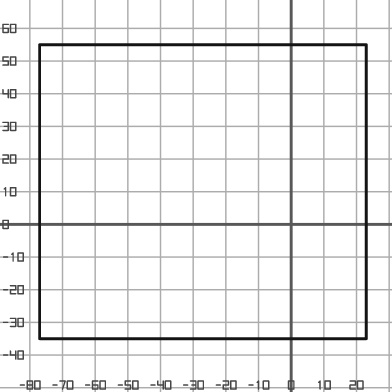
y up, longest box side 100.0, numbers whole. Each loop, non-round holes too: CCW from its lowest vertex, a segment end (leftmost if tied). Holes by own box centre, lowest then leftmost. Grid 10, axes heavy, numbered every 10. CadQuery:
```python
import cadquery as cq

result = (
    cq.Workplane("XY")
    .moveTo(-77.0, -35.0)
    .lineTo(23.0, -35.0)
    .lineTo(23.0, 55.0)
    .lineTo(-77.0, 55.0)
    .close()
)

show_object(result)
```